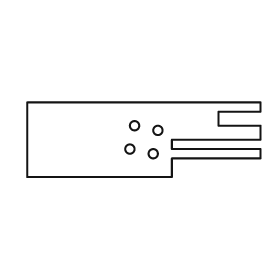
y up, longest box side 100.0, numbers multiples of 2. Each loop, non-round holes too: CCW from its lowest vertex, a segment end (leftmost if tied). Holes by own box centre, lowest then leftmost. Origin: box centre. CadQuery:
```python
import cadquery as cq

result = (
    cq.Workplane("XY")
    .moveTo(-50.0, -16.0)
    .lineTo(12.0, -16.0)
    .lineTo(12.0, -8.0)
    .lineTo(50.0, -8.0)
    .lineTo(50.0, -4.0)
    .lineTo(12.0, -4.0)
    .lineTo(12.0, 0.0)
    .lineTo(50.0, 0.0)
    .lineTo(50.0, 6.0)
    .lineTo(32.0, 6.0)
    .lineTo(32.0, 12.0)
    .lineTo(50.0, 12.0)
    .lineTo(50.0, 16.0)
    .lineTo(-50.0, 16.0)
    .close()
    .moveTo(4.0, -6.0)
    .circle(2.0)
    .moveTo(-6.0, -4.0)
    .circle(2.0)
    .moveTo(6.0, 4.0)
    .circle(2.0)
    .moveTo(-4.0, 6.0)
    .circle(2.0)
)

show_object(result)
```